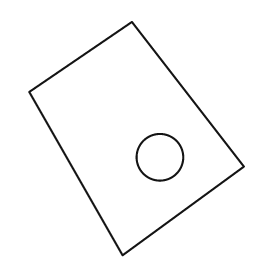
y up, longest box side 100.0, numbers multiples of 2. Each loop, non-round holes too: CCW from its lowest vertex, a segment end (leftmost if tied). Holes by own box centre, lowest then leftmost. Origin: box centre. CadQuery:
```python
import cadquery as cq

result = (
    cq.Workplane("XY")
    .moveTo(-6.0, -50.0)
    .lineTo(46.0, -12.0)
    .lineTo(-2.0, 50.0)
    .lineTo(-46.0, 20.0)
    .close()
    .moveTo(10.0, -8.0)
    .circle(10.0)
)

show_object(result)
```